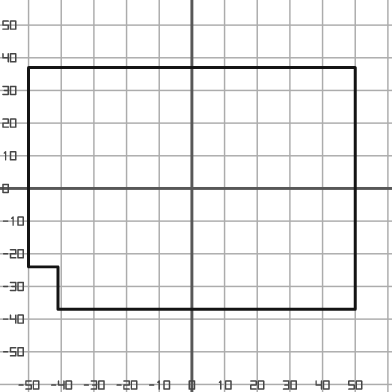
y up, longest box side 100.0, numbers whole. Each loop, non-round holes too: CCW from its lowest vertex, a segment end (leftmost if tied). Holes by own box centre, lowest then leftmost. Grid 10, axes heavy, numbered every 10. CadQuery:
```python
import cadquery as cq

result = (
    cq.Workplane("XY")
    .moveTo(-41.0, -37.0)
    .lineTo(50.0, -37.0)
    .lineTo(50.0, 37.0)
    .lineTo(-50.0, 37.0)
    .lineTo(-50.0, -24.0)
    .lineTo(-41.0, -24.0)
    .close()
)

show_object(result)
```